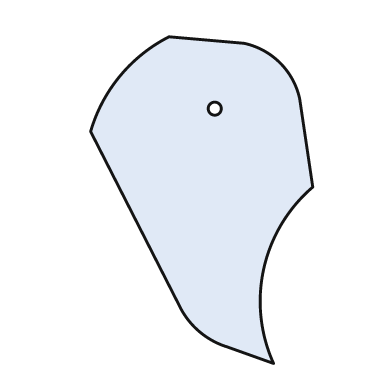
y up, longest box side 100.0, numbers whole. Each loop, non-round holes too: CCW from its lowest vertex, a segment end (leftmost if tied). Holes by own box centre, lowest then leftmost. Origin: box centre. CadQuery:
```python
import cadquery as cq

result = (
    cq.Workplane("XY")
    .moveTo(22.0, -50.0)
    .threePointArc((19.0, -21.0), (34.0, 4.0))
    .lineTo(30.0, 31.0)
    .threePointArc((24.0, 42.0), (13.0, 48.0))
    .lineTo(-10.0, 50.0)
    .threePointArc((-25.0, 38.0), (-34.0, 21.0))
    .lineTo(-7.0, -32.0)
    .threePointArc((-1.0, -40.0), (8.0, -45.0))
    .close()
    .moveTo(4.0, 28.0)
    .circle(2.0)
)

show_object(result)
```